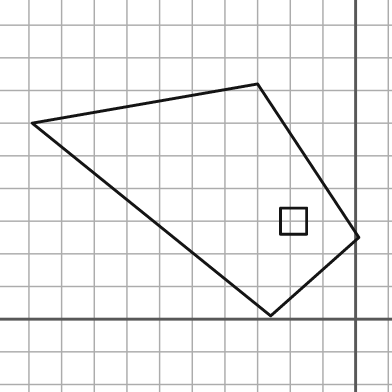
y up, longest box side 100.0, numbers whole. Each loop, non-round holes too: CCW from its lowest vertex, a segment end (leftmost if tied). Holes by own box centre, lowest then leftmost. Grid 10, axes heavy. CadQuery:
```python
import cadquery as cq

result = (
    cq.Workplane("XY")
    .moveTo(-26.0, 1.0)
    .lineTo(1.0, 25.0)
    .lineTo(-30.0, 72.0)
    .lineTo(-99.0, 60.0)
    .close()
    .moveTo(-23.0, 26.0)
    .lineTo(-15.0, 26.0)
    .lineTo(-15.0, 34.0)
    .lineTo(-23.0, 34.0)
    .close()
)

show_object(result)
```